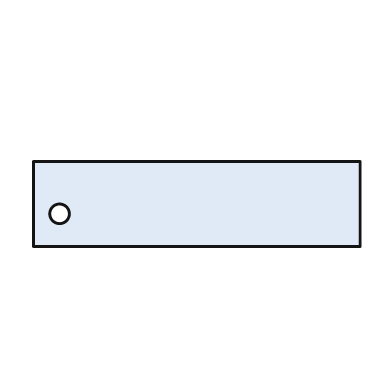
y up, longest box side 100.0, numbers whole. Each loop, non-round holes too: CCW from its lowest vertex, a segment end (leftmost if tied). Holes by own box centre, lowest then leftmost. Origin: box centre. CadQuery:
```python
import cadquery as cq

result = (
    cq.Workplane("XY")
    .moveTo(-50.0, -13.0)
    .lineTo(50.0, -13.0)
    .lineTo(50.0, 13.0)
    .lineTo(-50.0, 13.0)
    .close()
    .moveTo(-42.0, -3.0)
    .circle(3.0)
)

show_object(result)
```